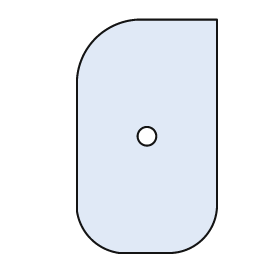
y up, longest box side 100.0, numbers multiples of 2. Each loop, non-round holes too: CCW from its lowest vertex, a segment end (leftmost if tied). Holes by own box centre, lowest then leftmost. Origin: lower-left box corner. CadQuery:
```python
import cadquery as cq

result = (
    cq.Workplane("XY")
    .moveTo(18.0, 0.0)
    .lineTo(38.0, 0.0)
    .threePointArc((54.0, 6.0), (60.0, 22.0))
    .lineTo(60.0, 100.0)
    .lineTo(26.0, 100.0)
    .threePointArc((8.0, 92.0), (0.0, 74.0))
    .lineTo(0.0, 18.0)
    .threePointArc((6.0, 6.0), (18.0, 0.0))
    .close()
    .moveTo(30.0, 50.0)
    .circle(4.0)
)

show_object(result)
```